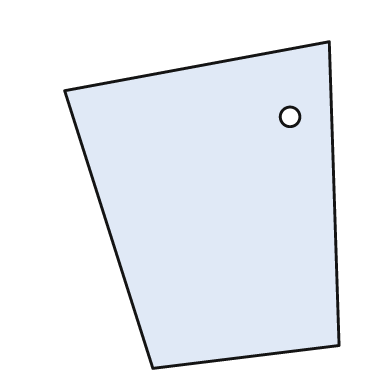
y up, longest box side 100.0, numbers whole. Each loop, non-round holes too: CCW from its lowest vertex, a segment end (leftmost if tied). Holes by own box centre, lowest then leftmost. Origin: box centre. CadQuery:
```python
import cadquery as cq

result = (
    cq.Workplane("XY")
    .moveTo(-15.0, -50.0)
    .lineTo(42.0, -43.0)
    .lineTo(39.0, 50.0)
    .lineTo(-42.0, 35.0)
    .close()
    .moveTo(27.0, 27.0)
    .circle(3.0)
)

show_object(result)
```